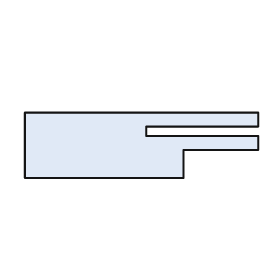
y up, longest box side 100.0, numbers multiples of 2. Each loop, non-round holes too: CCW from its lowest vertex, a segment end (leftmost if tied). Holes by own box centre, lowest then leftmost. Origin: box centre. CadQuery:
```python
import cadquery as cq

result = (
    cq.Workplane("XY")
    .moveTo(-50.0, -14.0)
    .lineTo(18.0, -14.0)
    .lineTo(18.0, -2.0)
    .lineTo(50.0, -2.0)
    .lineTo(50.0, 4.0)
    .lineTo(2.0, 4.0)
    .lineTo(2.0, 8.0)
    .lineTo(50.0, 8.0)
    .lineTo(50.0, 14.0)
    .lineTo(-50.0, 14.0)
    .close()
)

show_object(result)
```